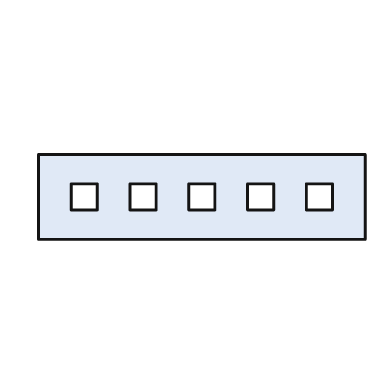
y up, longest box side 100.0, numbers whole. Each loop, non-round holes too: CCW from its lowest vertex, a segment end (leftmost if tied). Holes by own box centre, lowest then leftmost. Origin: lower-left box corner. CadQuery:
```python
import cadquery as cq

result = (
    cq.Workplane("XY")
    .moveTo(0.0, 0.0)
    .lineTo(100.0, 0.0)
    .lineTo(100.0, 26.0)
    .lineTo(0.0, 26.0)
    .close()
    .moveTo(10.0, 9.0)
    .lineTo(18.0, 9.0)
    .lineTo(18.0, 17.0)
    .lineTo(10.0, 17.0)
    .close()
    .moveTo(28.0, 9.0)
    .lineTo(36.0, 9.0)
    .lineTo(36.0, 17.0)
    .lineTo(28.0, 17.0)
    .close()
    .moveTo(46.0, 9.0)
    .lineTo(54.0, 9.0)
    .lineTo(54.0, 17.0)
    .lineTo(46.0, 17.0)
    .close()
    .moveTo(64.0, 9.0)
    .lineTo(72.0, 9.0)
    .lineTo(72.0, 17.0)
    .lineTo(64.0, 17.0)
    .close()
    .moveTo(82.0, 9.0)
    .lineTo(90.0, 9.0)
    .lineTo(90.0, 17.0)
    .lineTo(82.0, 17.0)
    .close()
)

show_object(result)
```